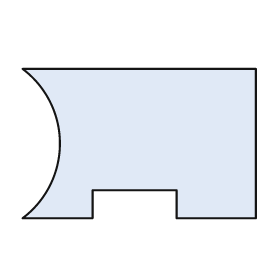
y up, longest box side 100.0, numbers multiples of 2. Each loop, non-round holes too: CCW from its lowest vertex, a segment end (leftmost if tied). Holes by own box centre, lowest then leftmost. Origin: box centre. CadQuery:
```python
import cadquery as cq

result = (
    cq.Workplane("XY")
    .moveTo(-50.0, -32.0)
    .lineTo(-20.0, -32.0)
    .lineTo(-20.0, -20.0)
    .lineTo(16.0, -20.0)
    .lineTo(16.0, -32.0)
    .lineTo(50.0, -32.0)
    .lineTo(50.0, 32.0)
    .lineTo(-50.0, 32.0)
    .threePointArc((-34.0, 0.0), (-50.0, -32.0))
    .close()
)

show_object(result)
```